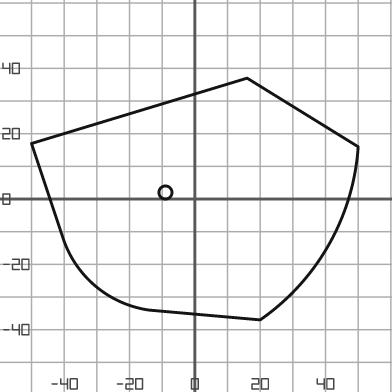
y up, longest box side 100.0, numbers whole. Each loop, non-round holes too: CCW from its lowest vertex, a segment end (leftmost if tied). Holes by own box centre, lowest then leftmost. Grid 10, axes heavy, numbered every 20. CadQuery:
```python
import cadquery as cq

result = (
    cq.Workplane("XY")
    .moveTo(20.0, -37.0)
    .threePointArc((41.0, -14.0), (50.0, 16.0))
    .lineTo(16.0, 37.0)
    .lineTo(-50.0, 17.0)
    .lineTo(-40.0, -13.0)
    .threePointArc((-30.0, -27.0), (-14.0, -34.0))
    .close()
    .moveTo(-9.0, 2.0)
    .circle(2.0)
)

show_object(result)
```